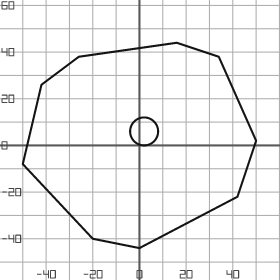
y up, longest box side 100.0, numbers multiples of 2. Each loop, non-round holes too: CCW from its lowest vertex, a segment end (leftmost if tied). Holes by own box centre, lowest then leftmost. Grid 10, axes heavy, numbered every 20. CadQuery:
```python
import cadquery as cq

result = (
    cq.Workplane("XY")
    .moveTo(0.0, -44.0)
    .lineTo(42.0, -22.0)
    .lineTo(50.0, 2.0)
    .lineTo(34.0, 38.0)
    .lineTo(16.0, 44.0)
    .lineTo(-26.0, 38.0)
    .lineTo(-42.0, 26.0)
    .lineTo(-50.0, -8.0)
    .lineTo(-20.0, -40.0)
    .close()
    .moveTo(2.0, 6.0)
    .circle(6.0)
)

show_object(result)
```